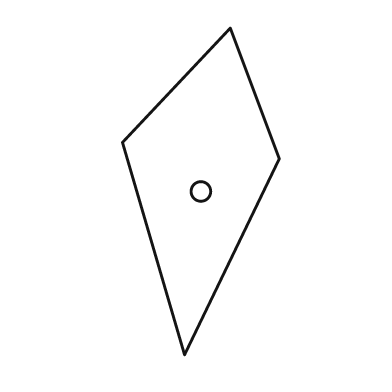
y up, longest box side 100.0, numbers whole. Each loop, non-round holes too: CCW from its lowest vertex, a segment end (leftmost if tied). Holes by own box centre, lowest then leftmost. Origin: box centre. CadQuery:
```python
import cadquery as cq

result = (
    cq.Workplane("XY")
    .moveTo(-5.0, -50.0)
    .lineTo(24.0, 10.0)
    .lineTo(9.0, 50.0)
    .lineTo(-24.0, 15.0)
    .close()
    .moveTo(0.0, 0.0)
    .circle(3.0)
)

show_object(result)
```